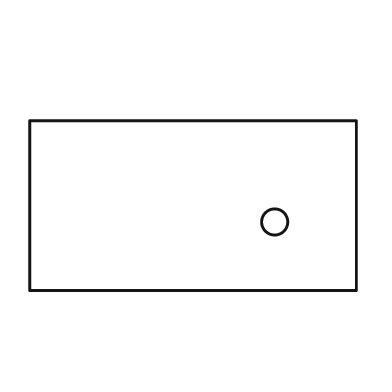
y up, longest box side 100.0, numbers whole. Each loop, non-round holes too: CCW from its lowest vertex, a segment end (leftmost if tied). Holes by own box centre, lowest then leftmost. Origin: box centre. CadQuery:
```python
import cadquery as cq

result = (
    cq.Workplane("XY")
    .moveTo(-50.0, -26.0)
    .lineTo(50.0, -26.0)
    .lineTo(50.0, 26.0)
    .lineTo(-50.0, 26.0)
    .close()
    .moveTo(25.0, -5.0)
    .circle(4.0)
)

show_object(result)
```